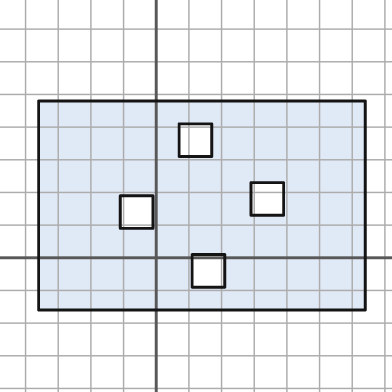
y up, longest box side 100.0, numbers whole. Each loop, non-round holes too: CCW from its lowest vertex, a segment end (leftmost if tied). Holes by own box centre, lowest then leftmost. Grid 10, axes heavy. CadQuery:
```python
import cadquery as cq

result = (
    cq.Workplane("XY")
    .moveTo(-36.0, -16.0)
    .lineTo(64.0, -16.0)
    .lineTo(64.0, 48.0)
    .lineTo(-36.0, 48.0)
    .close()
    .moveTo(11.0, -9.0)
    .lineTo(21.0, -9.0)
    .lineTo(21.0, 1.0)
    .lineTo(11.0, 1.0)
    .close()
    .moveTo(-11.0, 9.0)
    .lineTo(-1.0, 9.0)
    .lineTo(-1.0, 19.0)
    .lineTo(-11.0, 19.0)
    .close()
    .moveTo(29.0, 13.0)
    .lineTo(39.0, 13.0)
    .lineTo(39.0, 23.0)
    .lineTo(29.0, 23.0)
    .close()
    .moveTo(7.0, 31.0)
    .lineTo(17.0, 31.0)
    .lineTo(17.0, 41.0)
    .lineTo(7.0, 41.0)
    .close()
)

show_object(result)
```